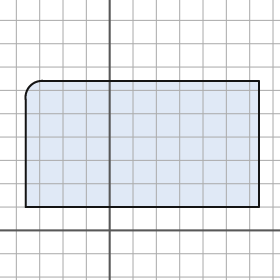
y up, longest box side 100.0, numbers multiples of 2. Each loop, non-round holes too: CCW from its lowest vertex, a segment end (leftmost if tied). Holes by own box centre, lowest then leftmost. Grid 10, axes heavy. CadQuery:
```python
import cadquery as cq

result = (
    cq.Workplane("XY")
    .moveTo(-36.0, 10.0)
    .lineTo(64.0, 10.0)
    .lineTo(64.0, 64.0)
    .lineTo(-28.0, 64.0)
    .threePointArc((-34.0, 62.0), (-36.0, 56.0))
    .close()
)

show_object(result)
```